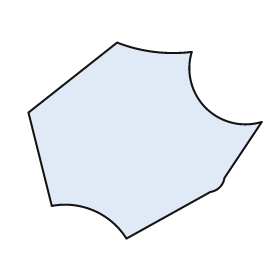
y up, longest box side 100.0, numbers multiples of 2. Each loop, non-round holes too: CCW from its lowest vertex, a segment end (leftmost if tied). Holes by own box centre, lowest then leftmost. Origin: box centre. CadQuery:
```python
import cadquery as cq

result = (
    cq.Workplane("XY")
    .moveTo(-8.0, -42.0)
    .lineTo(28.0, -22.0)
    .threePointArc((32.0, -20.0), (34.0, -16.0))
    .lineTo(50.0, 8.0)
    .threePointArc((26.0, 14.0), (20.0, 38.0))
    .threePointArc((4.0, 38.0), (-12.0, 42.0))
    .lineTo(-50.0, 12.0)
    .lineTo(-40.0, -28.0)
    .threePointArc((-22.0, -30.0), (-8.0, -42.0))
    .close()
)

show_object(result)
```